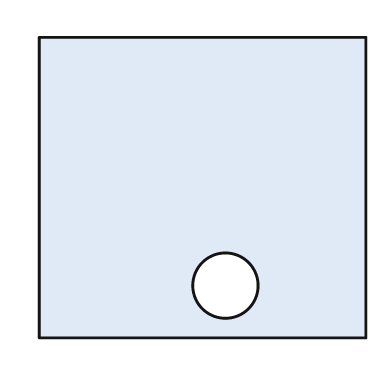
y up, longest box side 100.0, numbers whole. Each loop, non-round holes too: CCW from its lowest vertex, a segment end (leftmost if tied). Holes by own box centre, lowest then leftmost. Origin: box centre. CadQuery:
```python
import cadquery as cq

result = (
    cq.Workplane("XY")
    .moveTo(-50.0, -46.0)
    .lineTo(50.0, -46.0)
    .lineTo(50.0, 46.0)
    .lineTo(-50.0, 46.0)
    .close()
    .moveTo(7.0, -30.0)
    .circle(10.0)
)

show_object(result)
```